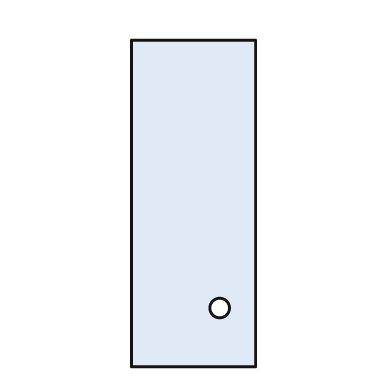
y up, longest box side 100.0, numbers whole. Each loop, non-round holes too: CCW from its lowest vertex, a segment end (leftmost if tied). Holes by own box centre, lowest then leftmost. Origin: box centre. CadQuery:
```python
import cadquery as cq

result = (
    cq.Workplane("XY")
    .moveTo(-19.0, -50.0)
    .lineTo(19.0, -50.0)
    .lineTo(19.0, 50.0)
    .lineTo(-19.0, 50.0)
    .close()
    .moveTo(8.0, -32.0)
    .circle(3.0)
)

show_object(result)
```